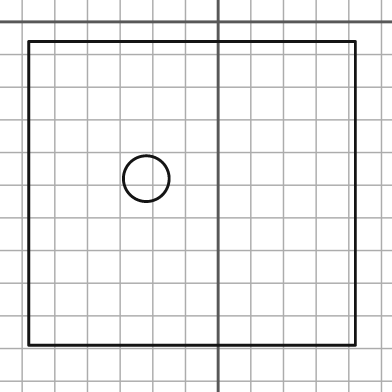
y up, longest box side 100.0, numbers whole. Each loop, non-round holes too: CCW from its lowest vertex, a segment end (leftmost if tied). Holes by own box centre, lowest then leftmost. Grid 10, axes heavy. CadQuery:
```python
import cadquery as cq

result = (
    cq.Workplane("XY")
    .moveTo(-58.0, -99.0)
    .lineTo(42.0, -99.0)
    .lineTo(42.0, -6.0)
    .lineTo(-58.0, -6.0)
    .close()
    .moveTo(-22.0, -48.0)
    .circle(7.0)
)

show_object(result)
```